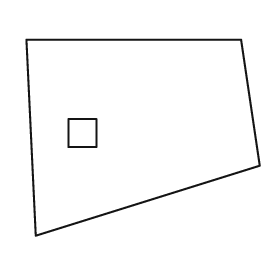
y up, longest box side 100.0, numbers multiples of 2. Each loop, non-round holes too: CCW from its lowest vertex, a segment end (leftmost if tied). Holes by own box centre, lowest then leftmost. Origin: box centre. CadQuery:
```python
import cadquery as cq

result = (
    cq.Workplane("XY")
    .moveTo(-46.0, -42.0)
    .lineTo(50.0, -12.0)
    .lineTo(42.0, 42.0)
    .lineTo(-50.0, 42.0)
    .close()
    .moveTo(-32.0, -4.0)
    .lineTo(-20.0, -4.0)
    .lineTo(-20.0, 8.0)
    .lineTo(-32.0, 8.0)
    .close()
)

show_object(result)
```